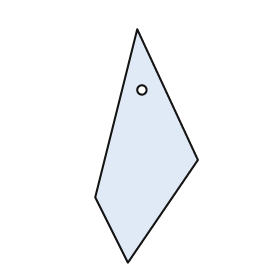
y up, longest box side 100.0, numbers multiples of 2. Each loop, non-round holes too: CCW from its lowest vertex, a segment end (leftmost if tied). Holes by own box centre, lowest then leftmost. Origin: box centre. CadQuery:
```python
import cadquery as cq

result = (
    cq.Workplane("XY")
    .moveTo(-8.0, -50.0)
    .lineTo(22.0, -6.0)
    .lineTo(-4.0, 50.0)
    .lineTo(-22.0, -22.0)
    .close()
    .moveTo(-2.0, 24.0)
    .circle(2.0)
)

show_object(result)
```